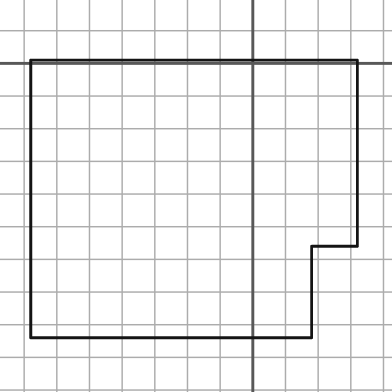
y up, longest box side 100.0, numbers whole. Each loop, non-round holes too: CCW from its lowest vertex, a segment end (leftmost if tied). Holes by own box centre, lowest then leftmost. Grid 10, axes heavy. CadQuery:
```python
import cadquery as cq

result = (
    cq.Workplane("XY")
    .moveTo(-68.0, -84.0)
    .lineTo(18.0, -84.0)
    .lineTo(18.0, -56.0)
    .lineTo(32.0, -56.0)
    .lineTo(32.0, 1.0)
    .lineTo(-68.0, 1.0)
    .close()
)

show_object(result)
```